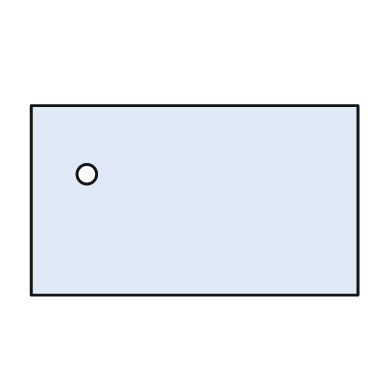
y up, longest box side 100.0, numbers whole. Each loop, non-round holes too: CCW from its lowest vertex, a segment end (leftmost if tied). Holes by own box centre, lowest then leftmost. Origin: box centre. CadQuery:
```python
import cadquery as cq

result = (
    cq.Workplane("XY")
    .moveTo(-50.0, -29.0)
    .lineTo(50.0, -29.0)
    .lineTo(50.0, 29.0)
    .lineTo(-50.0, 29.0)
    .close()
    .moveTo(-33.0, 8.0)
    .circle(3.0)
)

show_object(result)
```